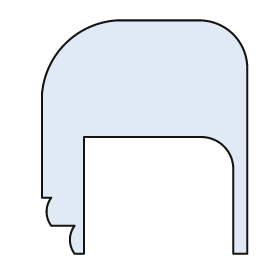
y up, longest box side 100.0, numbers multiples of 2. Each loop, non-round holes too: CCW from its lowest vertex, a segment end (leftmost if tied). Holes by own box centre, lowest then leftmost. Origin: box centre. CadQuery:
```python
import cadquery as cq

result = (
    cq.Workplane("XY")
    .moveTo(-30.0, -50.0)
    .lineTo(-26.0, -50.0)
    .lineTo(-26.0, 0.0)
    .lineTo(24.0, 0.0)
    .threePointArc((34.0, -4.0), (38.0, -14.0))
    .lineTo(38.0, -50.0)
    .lineTo(44.0, -50.0)
    .lineTo(44.0, 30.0)
    .threePointArc((38.0, 44.0), (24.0, 50.0))
    .lineTo(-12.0, 50.0)
    .threePointArc((-34.0, 40.0), (-44.0, 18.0))
    .lineTo(-44.0, -26.0)
    .lineTo(-40.0, -26.0)
    .threePointArc((-42.0, -32.0), (-40.0, -38.0))
    .lineTo(-30.0, -38.0)
    .threePointArc((-32.0, -44.0), (-30.0, -50.0))
    .close()
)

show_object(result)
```